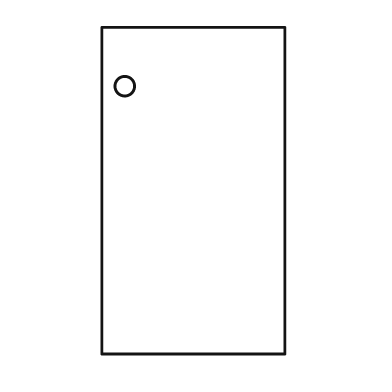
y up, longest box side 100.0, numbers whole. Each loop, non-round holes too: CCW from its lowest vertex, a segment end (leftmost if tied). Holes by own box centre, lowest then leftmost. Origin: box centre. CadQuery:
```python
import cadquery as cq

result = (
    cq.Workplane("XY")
    .moveTo(-28.0, -50.0)
    .lineTo(28.0, -50.0)
    .lineTo(28.0, 50.0)
    .lineTo(-28.0, 50.0)
    .close()
    .moveTo(-21.0, 32.0)
    .circle(3.0)
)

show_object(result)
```